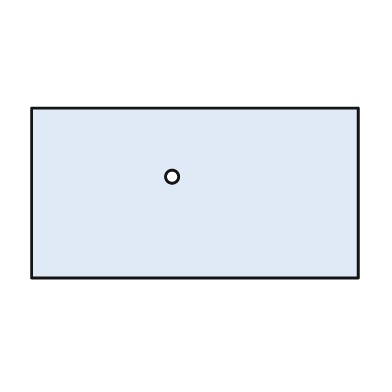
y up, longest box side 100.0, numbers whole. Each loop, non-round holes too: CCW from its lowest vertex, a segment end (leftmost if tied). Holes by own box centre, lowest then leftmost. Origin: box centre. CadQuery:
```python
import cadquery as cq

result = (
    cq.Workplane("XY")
    .moveTo(-50.0, -26.0)
    .lineTo(50.0, -26.0)
    .lineTo(50.0, 26.0)
    .lineTo(-50.0, 26.0)
    .close()
    .moveTo(-7.0, 5.0)
    .circle(2.0)
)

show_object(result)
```